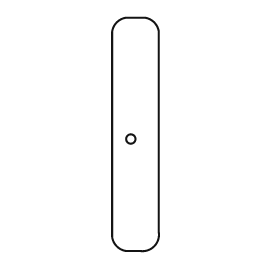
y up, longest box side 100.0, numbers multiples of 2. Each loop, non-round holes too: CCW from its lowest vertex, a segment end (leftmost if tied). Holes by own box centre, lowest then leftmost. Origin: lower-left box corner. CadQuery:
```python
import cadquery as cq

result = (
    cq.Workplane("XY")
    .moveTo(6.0, 0.0)
    .lineTo(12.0, 0.0)
    .threePointArc((18.0, 2.0), (20.0, 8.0))
    .lineTo(20.0, 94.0)
    .threePointArc((18.0, 98.0), (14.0, 100.0))
    .lineTo(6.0, 100.0)
    .threePointArc((2.0, 98.0), (0.0, 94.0))
    .lineTo(0.0, 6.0)
    .threePointArc((2.0, 2.0), (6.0, 0.0))
    .close()
    .moveTo(8.0, 48.0)
    .circle(2.0)
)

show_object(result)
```